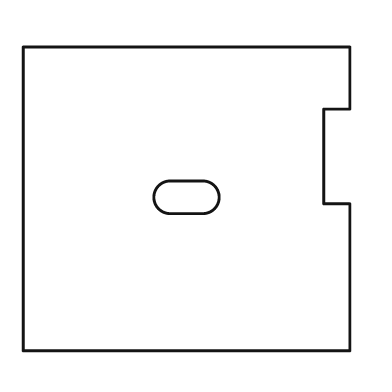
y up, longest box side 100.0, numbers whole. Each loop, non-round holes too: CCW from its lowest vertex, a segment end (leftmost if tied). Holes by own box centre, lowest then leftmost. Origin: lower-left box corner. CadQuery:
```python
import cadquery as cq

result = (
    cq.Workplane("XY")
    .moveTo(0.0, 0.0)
    .lineTo(100.0, 0.0)
    .lineTo(100.0, 45.0)
    .lineTo(92.0, 45.0)
    .lineTo(92.0, 74.0)
    .lineTo(100.0, 74.0)
    .lineTo(100.0, 93.0)
    .lineTo(0.0, 93.0)
    .close()
    .moveTo(45.0, 42.0)
    .lineTo(55.0, 42.0)
    .threePointArc((60.0, 47.0), (55.0, 52.0))
    .lineTo(45.0, 52.0)
    .threePointArc((40.0, 47.0), (45.0, 42.0))
    .close()
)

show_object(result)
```